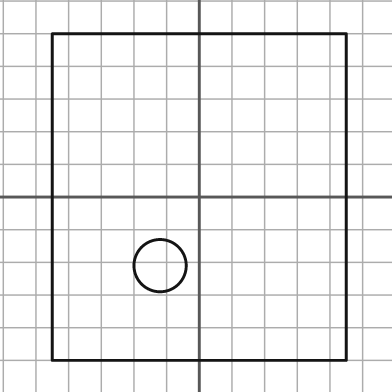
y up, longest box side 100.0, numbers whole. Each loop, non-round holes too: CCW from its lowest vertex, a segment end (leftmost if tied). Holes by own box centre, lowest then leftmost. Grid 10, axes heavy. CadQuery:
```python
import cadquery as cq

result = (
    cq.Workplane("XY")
    .moveTo(-45.0, -50.0)
    .lineTo(45.0, -50.0)
    .lineTo(45.0, 50.0)
    .lineTo(-45.0, 50.0)
    .close()
    .moveTo(-12.0, -21.0)
    .circle(8.0)
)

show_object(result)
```